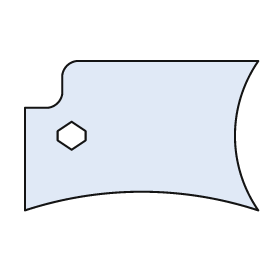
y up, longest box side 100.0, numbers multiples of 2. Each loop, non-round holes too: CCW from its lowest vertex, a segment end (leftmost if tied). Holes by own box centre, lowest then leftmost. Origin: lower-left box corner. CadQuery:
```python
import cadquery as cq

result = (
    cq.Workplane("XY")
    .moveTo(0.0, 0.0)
    .threePointArc((50.0, 8.0), (100.0, 0.0))
    .threePointArc((90.0, 32.0), (100.0, 64.0))
    .lineTo(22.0, 64.0)
    .threePointArc((18.0, 62.0), (16.0, 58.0))
    .lineTo(16.0, 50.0)
    .threePointArc((14.0, 46.0), (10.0, 44.0))
    .lineTo(0.0, 44.0)
    .close()
    .moveTo(20.0, 26.0)
    .lineTo(26.0, 30.0)
    .lineTo(26.0, 34.0)
    .lineTo(20.0, 38.0)
    .lineTo(14.0, 34.0)
    .lineTo(14.0, 30.0)
    .close()
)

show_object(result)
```